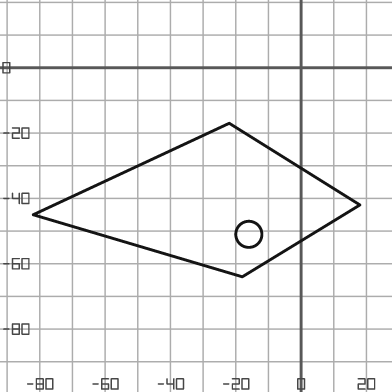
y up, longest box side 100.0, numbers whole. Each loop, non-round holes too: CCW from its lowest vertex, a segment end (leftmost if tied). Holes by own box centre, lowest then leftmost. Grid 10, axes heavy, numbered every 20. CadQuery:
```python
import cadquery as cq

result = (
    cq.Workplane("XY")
    .moveTo(-18.0, -64.0)
    .lineTo(18.0, -42.0)
    .lineTo(-22.0, -17.0)
    .lineTo(-82.0, -45.0)
    .close()
    .moveTo(-16.0, -51.0)
    .circle(4.0)
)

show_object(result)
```